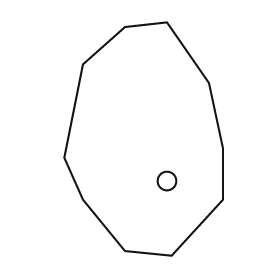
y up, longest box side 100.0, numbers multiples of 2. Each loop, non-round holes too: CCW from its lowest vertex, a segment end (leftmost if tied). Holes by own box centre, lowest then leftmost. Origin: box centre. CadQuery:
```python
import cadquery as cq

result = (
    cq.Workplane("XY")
    .moveTo(12.0, -50.0)
    .lineTo(34.0, -26.0)
    .lineTo(34.0, -4.0)
    .lineTo(28.0, 24.0)
    .lineTo(10.0, 50.0)
    .lineTo(-8.0, 48.0)
    .lineTo(-26.0, 32.0)
    .lineTo(-34.0, -8.0)
    .lineTo(-26.0, -26.0)
    .lineTo(-8.0, -48.0)
    .close()
    .moveTo(10.0, -18.0)
    .circle(4.0)
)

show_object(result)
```